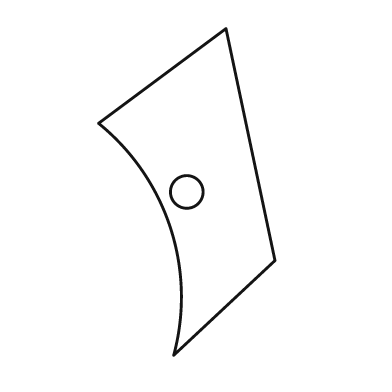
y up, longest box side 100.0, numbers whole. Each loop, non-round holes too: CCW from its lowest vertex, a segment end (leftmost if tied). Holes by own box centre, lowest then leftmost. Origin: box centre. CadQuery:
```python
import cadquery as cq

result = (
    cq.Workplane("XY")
    .moveTo(-4.0, -50.0)
    .lineTo(27.0, -21.0)
    .lineTo(12.0, 50.0)
    .lineTo(-27.0, 21.0)
    .threePointArc((-5.0, -11.0), (-4.0, -50.0))
    .close()
    .moveTo(0.0, 0.0)
    .circle(5.0)
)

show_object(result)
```